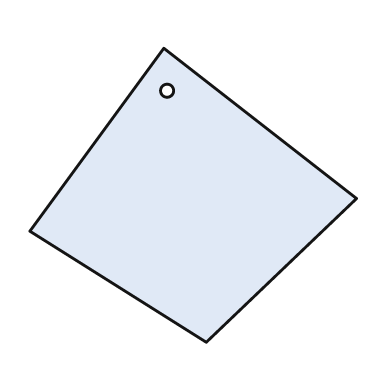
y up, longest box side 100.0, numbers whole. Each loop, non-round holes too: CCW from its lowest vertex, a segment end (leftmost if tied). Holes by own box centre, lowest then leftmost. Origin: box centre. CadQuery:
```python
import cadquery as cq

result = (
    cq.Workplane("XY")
    .moveTo(4.0, -45.0)
    .lineTo(50.0, -1.0)
    .lineTo(-9.0, 45.0)
    .lineTo(-50.0, -11.0)
    .close()
    .moveTo(-8.0, 32.0)
    .circle(2.0)
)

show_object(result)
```